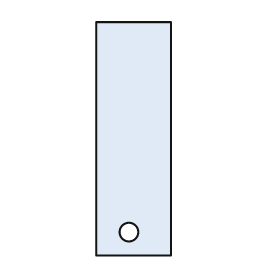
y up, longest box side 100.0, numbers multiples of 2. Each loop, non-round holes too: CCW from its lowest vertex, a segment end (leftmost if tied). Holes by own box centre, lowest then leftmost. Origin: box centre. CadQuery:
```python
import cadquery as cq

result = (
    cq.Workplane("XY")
    .moveTo(-16.0, -50.0)
    .lineTo(16.0, -50.0)
    .lineTo(16.0, 50.0)
    .lineTo(-16.0, 50.0)
    .close()
    .moveTo(-2.0, -40.0)
    .circle(4.0)
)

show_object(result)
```